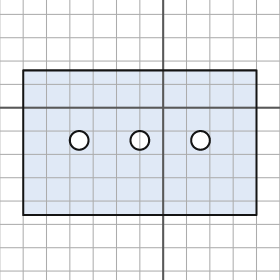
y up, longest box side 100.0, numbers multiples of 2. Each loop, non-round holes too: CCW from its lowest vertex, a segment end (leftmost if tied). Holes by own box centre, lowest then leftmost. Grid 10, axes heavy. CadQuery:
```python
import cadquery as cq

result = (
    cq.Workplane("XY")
    .moveTo(-60.0, -46.0)
    .lineTo(40.0, -46.0)
    .lineTo(40.0, 16.0)
    .lineTo(-60.0, 16.0)
    .close()
    .moveTo(-36.0, -14.0)
    .circle(4.0)
    .moveTo(-10.0, -14.0)
    .circle(4.0)
    .moveTo(16.0, -14.0)
    .circle(4.0)
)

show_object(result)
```